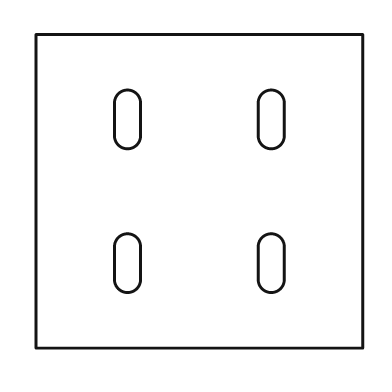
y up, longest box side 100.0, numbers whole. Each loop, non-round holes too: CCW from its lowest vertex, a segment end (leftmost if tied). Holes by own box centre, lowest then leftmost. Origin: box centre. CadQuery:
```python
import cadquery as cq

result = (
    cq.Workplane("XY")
    .moveTo(-50.0, -48.0)
    .lineTo(50.0, -48.0)
    .lineTo(50.0, 48.0)
    .lineTo(-50.0, 48.0)
    .close()
    .moveTo(-26.0, -27.0)
    .threePointArc((-22.0, -31.0), (-18.0, -27.0))
    .lineTo(-18.0, -17.0)
    .threePointArc((-22.0, -13.0), (-26.0, -17.0))
    .close()
    .moveTo(18.0, -27.0)
    .threePointArc((22.0, -31.0), (26.0, -27.0))
    .lineTo(26.0, -17.0)
    .threePointArc((22.0, -13.0), (18.0, -17.0))
    .close()
    .moveTo(-26.0, 17.0)
    .threePointArc((-22.0, 13.0), (-18.0, 17.0))
    .lineTo(-18.0, 27.0)
    .threePointArc((-22.0, 31.0), (-26.0, 27.0))
    .close()
    .moveTo(18.0, 17.0)
    .threePointArc((22.0, 13.0), (26.0, 17.0))
    .lineTo(26.0, 27.0)
    .threePointArc((22.0, 31.0), (18.0, 27.0))
    .close()
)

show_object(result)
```